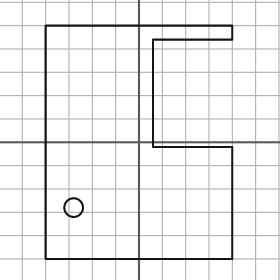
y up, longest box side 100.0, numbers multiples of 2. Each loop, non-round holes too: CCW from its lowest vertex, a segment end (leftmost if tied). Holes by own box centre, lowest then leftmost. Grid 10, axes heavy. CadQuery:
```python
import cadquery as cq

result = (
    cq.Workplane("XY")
    .moveTo(-40.0, -50.0)
    .lineTo(40.0, -50.0)
    .lineTo(40.0, -2.0)
    .lineTo(6.0, -2.0)
    .lineTo(6.0, 44.0)
    .lineTo(40.0, 44.0)
    .lineTo(40.0, 50.0)
    .lineTo(-40.0, 50.0)
    .close()
    .moveTo(-28.0, -28.0)
    .circle(4.0)
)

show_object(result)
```